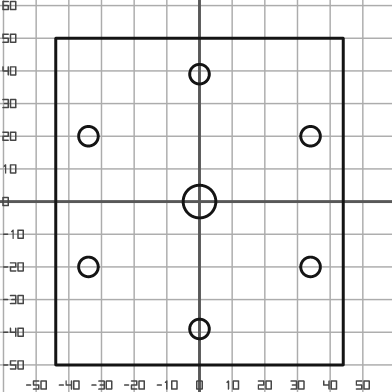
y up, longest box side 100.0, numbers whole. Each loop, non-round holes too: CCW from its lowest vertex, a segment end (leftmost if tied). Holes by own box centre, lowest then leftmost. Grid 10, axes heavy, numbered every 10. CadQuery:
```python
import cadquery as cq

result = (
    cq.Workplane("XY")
    .moveTo(-44.0, -50.0)
    .lineTo(44.0, -50.0)
    .lineTo(44.0, 50.0)
    .lineTo(-44.0, 50.0)
    .close()
    .moveTo(0.0, -39.0)
    .circle(3.0)
    .moveTo(-34.0, -20.0)
    .circle(3.0)
    .moveTo(34.0, -20.0)
    .circle(3.0)
    .moveTo(0.0, 0.0)
    .circle(5.0)
    .moveTo(-34.0, 20.0)
    .circle(3.0)
    .moveTo(34.0, 20.0)
    .circle(3.0)
    .moveTo(0.0, 39.0)
    .circle(3.0)
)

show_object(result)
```